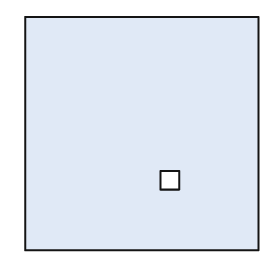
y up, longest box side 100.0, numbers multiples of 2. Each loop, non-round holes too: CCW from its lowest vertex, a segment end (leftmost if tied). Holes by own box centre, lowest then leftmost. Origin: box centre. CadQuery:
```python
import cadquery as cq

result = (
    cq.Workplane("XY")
    .moveTo(-50.0, -50.0)
    .lineTo(50.0, -50.0)
    .lineTo(50.0, 50.0)
    .lineTo(-50.0, 50.0)
    .close()
    .moveTo(8.0, -24.0)
    .lineTo(16.0, -24.0)
    .lineTo(16.0, -16.0)
    .lineTo(8.0, -16.0)
    .close()
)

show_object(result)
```